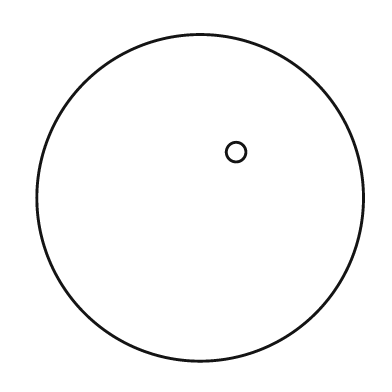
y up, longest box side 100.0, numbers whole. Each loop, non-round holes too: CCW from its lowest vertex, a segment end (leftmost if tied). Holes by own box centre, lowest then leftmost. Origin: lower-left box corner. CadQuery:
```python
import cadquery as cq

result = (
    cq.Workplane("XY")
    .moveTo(50.0, 50.0)
    .circle(50.0)
    .moveTo(61.0, 64.0)
    .circle(3.0)
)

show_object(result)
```